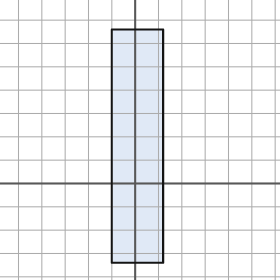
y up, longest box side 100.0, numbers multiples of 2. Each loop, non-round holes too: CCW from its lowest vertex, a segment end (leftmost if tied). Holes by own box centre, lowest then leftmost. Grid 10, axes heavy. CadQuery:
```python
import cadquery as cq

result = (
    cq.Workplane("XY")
    .moveTo(-10.0, -34.0)
    .lineTo(12.0, -34.0)
    .lineTo(12.0, 66.0)
    .lineTo(-10.0, 66.0)
    .close()
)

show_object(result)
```